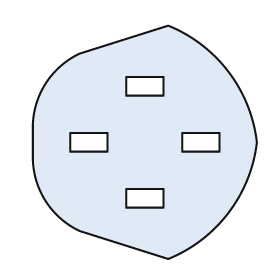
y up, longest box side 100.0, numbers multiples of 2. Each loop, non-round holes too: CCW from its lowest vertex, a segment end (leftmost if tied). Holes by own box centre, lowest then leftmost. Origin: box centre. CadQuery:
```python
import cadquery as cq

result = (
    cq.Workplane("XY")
    .moveTo(10.0, -50.0)
    .threePointArc((36.0, -30.0), (48.0, 0.0))
    .threePointArc((36.0, 30.0), (10.0, 50.0))
    .lineTo(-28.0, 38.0)
    .threePointArc((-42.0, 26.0), (-48.0, 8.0))
    .lineTo(-48.0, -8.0)
    .threePointArc((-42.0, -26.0), (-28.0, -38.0))
    .close()
    .moveTo(-8.0, -28.0)
    .lineTo(8.0, -28.0)
    .lineTo(8.0, -20.0)
    .lineTo(-8.0, -20.0)
    .close()
    .moveTo(-32.0, -4.0)
    .lineTo(-16.0, -4.0)
    .lineTo(-16.0, 4.0)
    .lineTo(-32.0, 4.0)
    .close()
    .moveTo(16.0, -4.0)
    .lineTo(32.0, -4.0)
    .lineTo(32.0, 4.0)
    .lineTo(16.0, 4.0)
    .close()
    .moveTo(-8.0, 20.0)
    .lineTo(8.0, 20.0)
    .lineTo(8.0, 28.0)
    .lineTo(-8.0, 28.0)
    .close()
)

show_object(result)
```